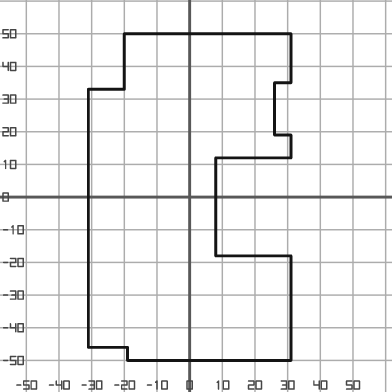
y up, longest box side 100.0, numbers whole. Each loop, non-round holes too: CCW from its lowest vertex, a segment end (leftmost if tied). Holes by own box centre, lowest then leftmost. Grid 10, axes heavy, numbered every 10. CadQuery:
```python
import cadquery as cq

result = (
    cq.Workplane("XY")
    .moveTo(-19.0, -50.0)
    .lineTo(31.0, -50.0)
    .lineTo(31.0, -18.0)
    .lineTo(8.0, -18.0)
    .lineTo(8.0, 12.0)
    .lineTo(31.0, 12.0)
    .lineTo(31.0, 19.0)
    .lineTo(26.0, 19.0)
    .lineTo(26.0, 35.0)
    .lineTo(31.0, 35.0)
    .lineTo(31.0, 50.0)
    .lineTo(-20.0, 50.0)
    .lineTo(-20.0, 33.0)
    .lineTo(-31.0, 33.0)
    .lineTo(-31.0, -46.0)
    .lineTo(-19.0, -46.0)
    .close()
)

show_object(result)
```